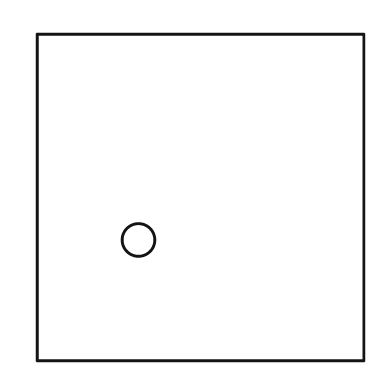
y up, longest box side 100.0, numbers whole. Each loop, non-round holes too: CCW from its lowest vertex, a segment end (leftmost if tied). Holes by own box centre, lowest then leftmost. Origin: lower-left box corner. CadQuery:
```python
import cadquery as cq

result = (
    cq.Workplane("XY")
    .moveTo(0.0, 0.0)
    .lineTo(100.0, 0.0)
    .lineTo(100.0, 100.0)
    .lineTo(0.0, 100.0)
    .close()
    .moveTo(31.0, 37.0)
    .circle(5.0)
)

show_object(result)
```